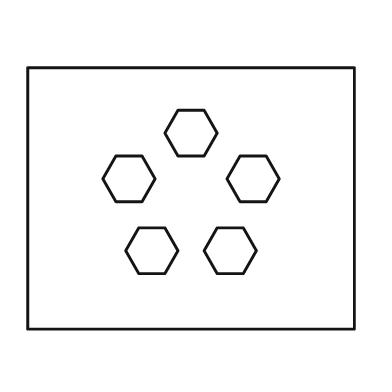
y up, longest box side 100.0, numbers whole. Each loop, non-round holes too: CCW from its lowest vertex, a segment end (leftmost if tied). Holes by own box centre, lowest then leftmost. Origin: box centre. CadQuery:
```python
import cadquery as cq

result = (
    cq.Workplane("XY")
    .moveTo(-50.0, -40.0)
    .lineTo(50.0, -40.0)
    .lineTo(50.0, 40.0)
    .lineTo(-50.0, 40.0)
    .close()
    .moveTo(-16.0, -23.0)
    .lineTo(-8.0, -23.0)
    .lineTo(-4.0, -16.0)
    .lineTo(-8.0, -9.0)
    .lineTo(-16.0, -9.0)
    .lineTo(-20.0, -16.0)
    .close()
    .moveTo(8.0, -23.0)
    .lineTo(16.0, -23.0)
    .lineTo(20.0, -16.0)
    .lineTo(16.0, -9.0)
    .lineTo(8.0, -9.0)
    .lineTo(4.0, -16.0)
    .close()
    .moveTo(-23.0, -1.0)
    .lineTo(-15.0, -1.0)
    .lineTo(-11.0, 6.0)
    .lineTo(-15.0, 13.0)
    .lineTo(-23.0, 13.0)
    .lineTo(-27.0, 6.0)
    .close()
    .moveTo(15.0, -1.0)
    .lineTo(23.0, -1.0)
    .lineTo(27.0, 6.0)
    .lineTo(23.0, 13.0)
    .lineTo(15.0, 13.0)
    .lineTo(11.0, 6.0)
    .close()
    .moveTo(-4.0, 13.0)
    .lineTo(4.0, 13.0)
    .lineTo(8.0, 20.0)
    .lineTo(4.0, 27.0)
    .lineTo(-4.0, 27.0)
    .lineTo(-8.0, 20.0)
    .close()
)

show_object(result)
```